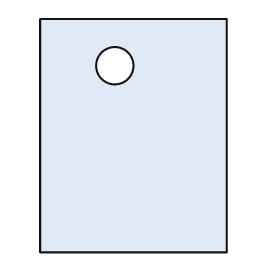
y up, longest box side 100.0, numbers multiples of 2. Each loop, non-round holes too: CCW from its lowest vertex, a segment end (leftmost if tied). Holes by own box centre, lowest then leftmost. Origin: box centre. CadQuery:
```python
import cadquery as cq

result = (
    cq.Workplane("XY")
    .moveTo(-40.0, -50.0)
    .lineTo(40.0, -50.0)
    .lineTo(40.0, 50.0)
    .lineTo(-40.0, 50.0)
    .close()
    .moveTo(-8.0, 30.0)
    .circle(8.0)
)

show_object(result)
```